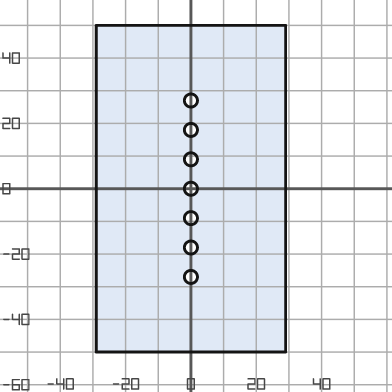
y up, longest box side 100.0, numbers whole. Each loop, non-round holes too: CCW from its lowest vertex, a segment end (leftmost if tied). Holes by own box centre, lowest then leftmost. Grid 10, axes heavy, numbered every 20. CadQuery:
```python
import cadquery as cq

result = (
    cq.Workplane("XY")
    .moveTo(-29.0, -50.0)
    .lineTo(29.0, -50.0)
    .lineTo(29.0, 50.0)
    .lineTo(-29.0, 50.0)
    .close()
    .moveTo(0.0, -27.0)
    .circle(2.0)
    .moveTo(0.0, -18.0)
    .circle(2.0)
    .moveTo(0.0, -9.0)
    .circle(2.0)
    .moveTo(0.0, 0.0)
    .circle(2.0)
    .moveTo(0.0, 9.0)
    .circle(2.0)
    .moveTo(0.0, 18.0)
    .circle(2.0)
    .moveTo(0.0, 27.0)
    .circle(2.0)
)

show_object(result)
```